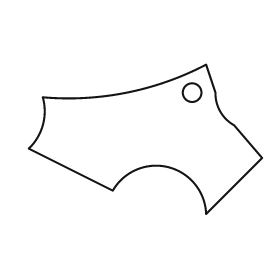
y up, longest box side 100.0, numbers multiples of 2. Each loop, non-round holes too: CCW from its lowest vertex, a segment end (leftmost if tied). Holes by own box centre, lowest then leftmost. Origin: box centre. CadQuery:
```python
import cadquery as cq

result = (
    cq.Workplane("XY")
    .moveTo(26.0, -32.0)
    .lineTo(50.0, -8.0)
    .lineTo(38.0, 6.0)
    .threePointArc((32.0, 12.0), (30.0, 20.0))
    .lineTo(26.0, 32.0)
    .threePointArc((-8.0, 20.0), (-44.0, 18.0))
    .threePointArc((-44.0, 6.0), (-50.0, -4.0))
    .lineTo(-14.0, -22.0)
    .threePointArc((10.0, -12.0), (26.0, -32.0))
    .close()
    .moveTo(20.0, 20.0)
    .circle(4.0)
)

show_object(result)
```